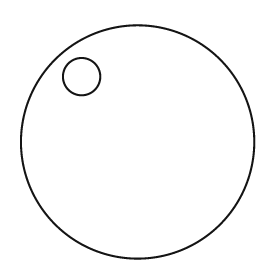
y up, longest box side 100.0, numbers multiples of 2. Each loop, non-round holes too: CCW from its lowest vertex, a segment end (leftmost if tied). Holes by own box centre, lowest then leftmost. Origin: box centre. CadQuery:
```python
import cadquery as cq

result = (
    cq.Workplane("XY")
    .moveTo(0.0, 0.0)
    .circle(50.0)
    .moveTo(-24.0, 28.0)
    .circle(8.0)
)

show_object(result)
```